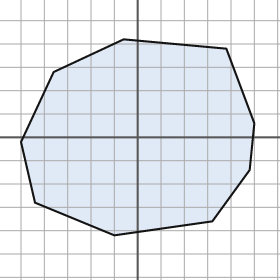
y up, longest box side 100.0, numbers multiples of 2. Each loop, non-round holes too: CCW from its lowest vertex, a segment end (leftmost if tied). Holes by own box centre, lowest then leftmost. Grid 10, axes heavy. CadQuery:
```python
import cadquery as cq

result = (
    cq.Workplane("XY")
    .moveTo(-10.0, -42.0)
    .lineTo(32.0, -36.0)
    .lineTo(48.0, -14.0)
    .lineTo(50.0, 6.0)
    .lineTo(38.0, 38.0)
    .lineTo(-6.0, 42.0)
    .lineTo(-36.0, 28.0)
    .lineTo(-50.0, -2.0)
    .lineTo(-44.0, -28.0)
    .close()
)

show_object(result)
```